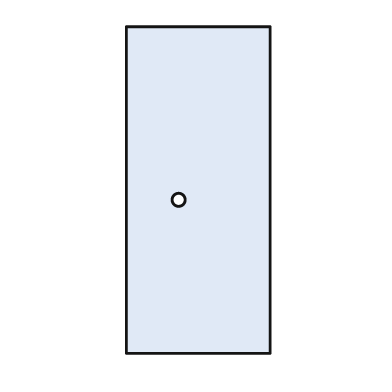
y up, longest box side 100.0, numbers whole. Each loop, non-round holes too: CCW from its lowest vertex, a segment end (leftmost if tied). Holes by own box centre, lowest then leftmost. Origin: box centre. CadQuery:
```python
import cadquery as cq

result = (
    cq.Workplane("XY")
    .moveTo(-22.0, -50.0)
    .lineTo(22.0, -50.0)
    .lineTo(22.0, 50.0)
    .lineTo(-22.0, 50.0)
    .close()
    .moveTo(-6.0, -3.0)
    .circle(2.0)
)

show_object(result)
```